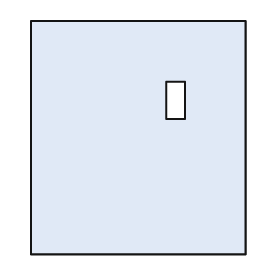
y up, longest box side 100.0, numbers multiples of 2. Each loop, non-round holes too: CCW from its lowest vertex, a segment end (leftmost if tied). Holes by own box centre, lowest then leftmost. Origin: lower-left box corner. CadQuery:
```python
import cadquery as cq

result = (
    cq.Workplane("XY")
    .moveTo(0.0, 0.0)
    .lineTo(92.0, 0.0)
    .lineTo(92.0, 100.0)
    .lineTo(0.0, 100.0)
    .close()
    .moveTo(58.0, 58.0)
    .lineTo(66.0, 58.0)
    .lineTo(66.0, 74.0)
    .lineTo(58.0, 74.0)
    .close()
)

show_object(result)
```